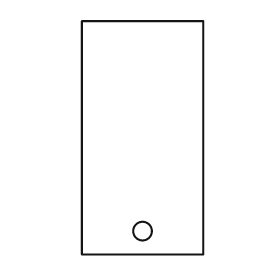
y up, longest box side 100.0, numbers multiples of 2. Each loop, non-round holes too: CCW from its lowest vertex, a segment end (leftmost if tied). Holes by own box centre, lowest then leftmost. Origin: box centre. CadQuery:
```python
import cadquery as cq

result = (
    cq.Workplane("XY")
    .moveTo(-26.0, -50.0)
    .lineTo(26.0, -50.0)
    .lineTo(26.0, 50.0)
    .lineTo(-26.0, 50.0)
    .close()
    .moveTo(0.0, -40.0)
    .circle(4.0)
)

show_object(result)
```